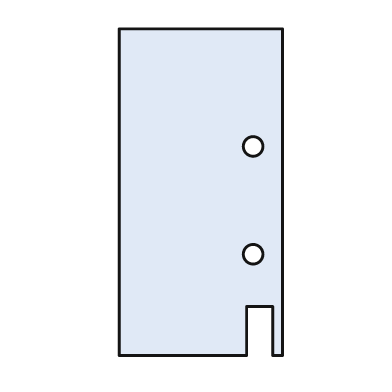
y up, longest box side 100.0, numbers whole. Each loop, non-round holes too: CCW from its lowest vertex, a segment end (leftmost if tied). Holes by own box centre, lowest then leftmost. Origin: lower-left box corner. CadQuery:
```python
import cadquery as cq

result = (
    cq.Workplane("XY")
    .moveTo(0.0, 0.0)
    .lineTo(39.0, 0.0)
    .lineTo(39.0, 15.0)
    .lineTo(47.0, 15.0)
    .lineTo(47.0, 0.0)
    .lineTo(50.0, 0.0)
    .lineTo(50.0, 100.0)
    .lineTo(0.0, 100.0)
    .close()
    .moveTo(41.0, 31.0)
    .circle(3.0)
    .moveTo(41.0, 64.0)
    .circle(3.0)
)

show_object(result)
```